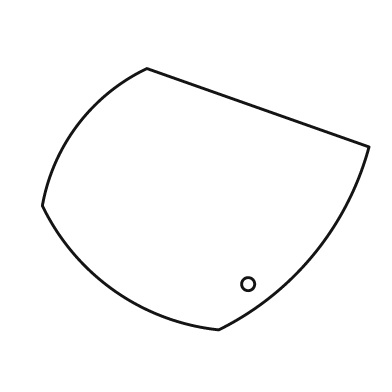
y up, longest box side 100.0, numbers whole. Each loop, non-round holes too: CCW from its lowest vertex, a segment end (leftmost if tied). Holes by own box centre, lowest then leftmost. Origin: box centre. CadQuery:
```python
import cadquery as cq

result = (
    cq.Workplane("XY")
    .moveTo(4.0, -40.0)
    .threePointArc((33.0, -17.0), (50.0, 16.0))
    .lineTo(-18.0, 40.0)
    .threePointArc((-39.0, 23.0), (-50.0, -2.0))
    .threePointArc((-28.0, -28.0), (4.0, -40.0))
    .close()
    .moveTo(13.0, -26.0)
    .circle(2.0)
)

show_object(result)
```